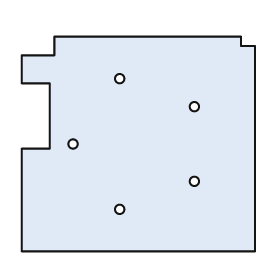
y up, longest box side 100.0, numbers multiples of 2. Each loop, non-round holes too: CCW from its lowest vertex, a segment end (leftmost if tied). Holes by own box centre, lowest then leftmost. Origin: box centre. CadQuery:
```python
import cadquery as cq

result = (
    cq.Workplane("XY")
    .moveTo(-50.0, -46.0)
    .lineTo(50.0, -46.0)
    .lineTo(50.0, 42.0)
    .lineTo(44.0, 42.0)
    .lineTo(44.0, 46.0)
    .lineTo(-36.0, 46.0)
    .lineTo(-36.0, 38.0)
    .lineTo(-50.0, 38.0)
    .lineTo(-50.0, 26.0)
    .lineTo(-38.0, 26.0)
    .lineTo(-38.0, -2.0)
    .lineTo(-50.0, -2.0)
    .close()
    .moveTo(-8.0, -28.0)
    .circle(2.0)
    .moveTo(24.0, -16.0)
    .circle(2.0)
    .moveTo(-28.0, 0.0)
    .circle(2.0)
    .moveTo(24.0, 16.0)
    .circle(2.0)
    .moveTo(-8.0, 28.0)
    .circle(2.0)
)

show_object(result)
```